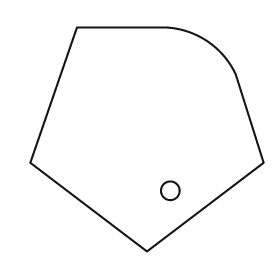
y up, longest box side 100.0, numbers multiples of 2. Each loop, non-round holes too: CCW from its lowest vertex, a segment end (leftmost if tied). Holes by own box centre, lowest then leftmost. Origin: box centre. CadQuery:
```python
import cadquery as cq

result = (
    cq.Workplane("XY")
    .moveTo(0.0, -48.0)
    .lineTo(50.0, -10.0)
    .lineTo(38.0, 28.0)
    .threePointArc((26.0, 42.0), (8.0, 48.0))
    .lineTo(-30.0, 48.0)
    .lineTo(-50.0, -10.0)
    .close()
    .moveTo(10.0, -22.0)
    .circle(4.0)
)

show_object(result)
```